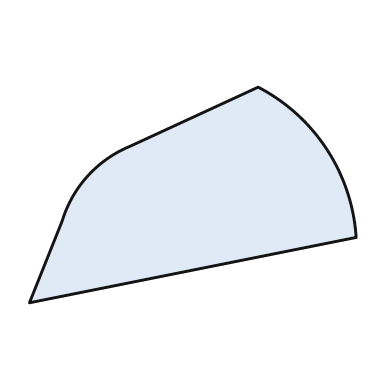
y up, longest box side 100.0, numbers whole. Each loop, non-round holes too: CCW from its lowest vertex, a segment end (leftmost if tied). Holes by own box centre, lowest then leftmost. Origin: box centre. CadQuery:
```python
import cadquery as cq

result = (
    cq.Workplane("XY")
    .moveTo(-50.0, -33.0)
    .lineTo(50.0, -13.0)
    .threePointArc((41.0, 14.0), (20.0, 33.0))
    .lineTo(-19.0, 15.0)
    .threePointArc((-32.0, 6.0), (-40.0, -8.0))
    .close()
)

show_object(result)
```